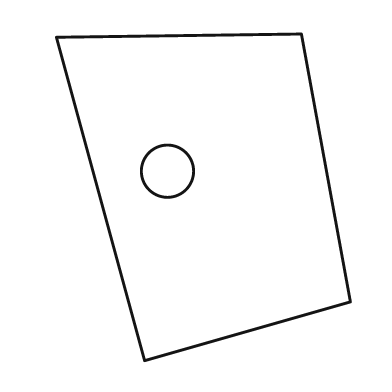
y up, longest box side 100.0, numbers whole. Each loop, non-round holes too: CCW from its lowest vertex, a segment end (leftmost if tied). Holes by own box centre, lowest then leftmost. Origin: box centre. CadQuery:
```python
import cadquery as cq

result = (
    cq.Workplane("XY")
    .moveTo(-18.0, -50.0)
    .lineTo(45.0, -32.0)
    .lineTo(30.0, 50.0)
    .lineTo(-45.0, 49.0)
    .close()
    .moveTo(-11.0, 8.0)
    .circle(8.0)
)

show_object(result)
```